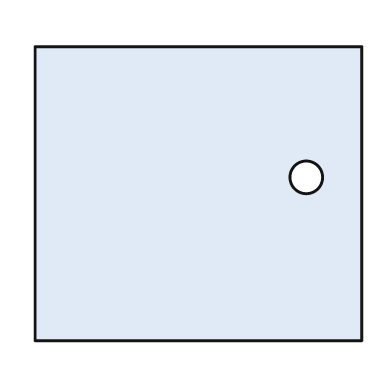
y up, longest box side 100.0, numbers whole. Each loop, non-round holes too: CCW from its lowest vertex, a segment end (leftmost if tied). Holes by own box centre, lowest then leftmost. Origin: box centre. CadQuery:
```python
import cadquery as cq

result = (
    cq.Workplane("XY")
    .moveTo(-50.0, -45.0)
    .lineTo(50.0, -45.0)
    .lineTo(50.0, 45.0)
    .lineTo(-50.0, 45.0)
    .close()
    .moveTo(33.0, 5.0)
    .circle(5.0)
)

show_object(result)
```